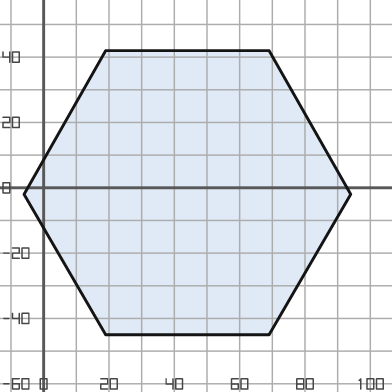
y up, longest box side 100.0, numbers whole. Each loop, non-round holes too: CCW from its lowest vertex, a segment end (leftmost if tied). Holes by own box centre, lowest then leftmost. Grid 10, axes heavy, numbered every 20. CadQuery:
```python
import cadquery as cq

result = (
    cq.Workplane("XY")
    .moveTo(19.0, -45.0)
    .lineTo(69.0, -45.0)
    .lineTo(94.0, -2.0)
    .lineTo(69.0, 42.0)
    .lineTo(19.0, 42.0)
    .lineTo(-6.0, -2.0)
    .close()
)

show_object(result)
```